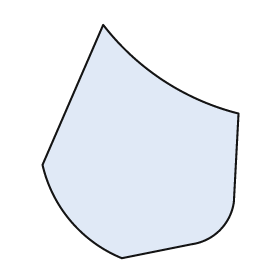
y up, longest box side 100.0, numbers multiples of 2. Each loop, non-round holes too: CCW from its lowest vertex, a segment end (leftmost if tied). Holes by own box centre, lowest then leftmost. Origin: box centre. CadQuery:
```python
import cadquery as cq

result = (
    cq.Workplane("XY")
    .moveTo(-8.0, -50.0)
    .lineTo(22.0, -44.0)
    .threePointArc((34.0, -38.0), (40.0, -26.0))
    .lineTo(42.0, 12.0)
    .threePointArc((10.0, 26.0), (-16.0, 50.0))
    .lineTo(-42.0, -10.0)
    .threePointArc((-30.0, -34.0), (-8.0, -50.0))
    .close()
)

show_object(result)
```